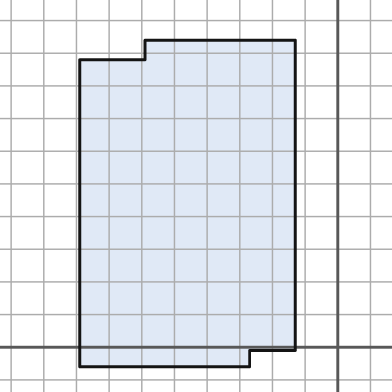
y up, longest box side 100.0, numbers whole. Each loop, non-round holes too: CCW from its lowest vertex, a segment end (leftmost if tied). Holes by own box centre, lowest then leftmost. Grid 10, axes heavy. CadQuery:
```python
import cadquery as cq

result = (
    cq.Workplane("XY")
    .moveTo(-79.0, -6.0)
    .lineTo(-27.0, -6.0)
    .lineTo(-27.0, -1.0)
    .lineTo(-13.0, -1.0)
    .lineTo(-13.0, 94.0)
    .lineTo(-59.0, 94.0)
    .lineTo(-59.0, 88.0)
    .lineTo(-79.0, 88.0)
    .close()
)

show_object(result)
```